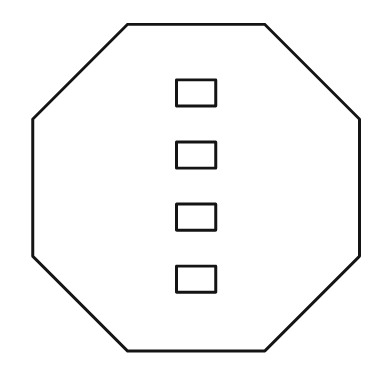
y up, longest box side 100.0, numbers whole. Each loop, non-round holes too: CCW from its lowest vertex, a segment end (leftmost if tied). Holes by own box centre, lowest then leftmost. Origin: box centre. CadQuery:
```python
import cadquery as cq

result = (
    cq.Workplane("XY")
    .moveTo(-21.0, -50.0)
    .lineTo(21.0, -50.0)
    .lineTo(50.0, -21.0)
    .lineTo(50.0, 21.0)
    .lineTo(21.0, 50.0)
    .lineTo(-21.0, 50.0)
    .lineTo(-50.0, 21.0)
    .lineTo(-50.0, -21.0)
    .close()
    .moveTo(-6.0, -32.0)
    .lineTo(6.0, -32.0)
    .lineTo(6.0, -24.0)
    .lineTo(-6.0, -24.0)
    .close()
    .moveTo(-6.0, -13.0)
    .lineTo(6.0, -13.0)
    .lineTo(6.0, -5.0)
    .lineTo(-6.0, -5.0)
    .close()
    .moveTo(-6.0, 6.0)
    .lineTo(6.0, 6.0)
    .lineTo(6.0, 14.0)
    .lineTo(-6.0, 14.0)
    .close()
    .moveTo(-6.0, 25.0)
    .lineTo(6.0, 25.0)
    .lineTo(6.0, 33.0)
    .lineTo(-6.0, 33.0)
    .close()
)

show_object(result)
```